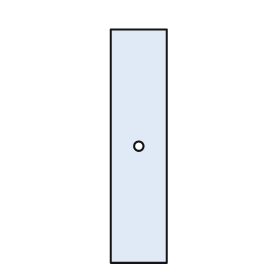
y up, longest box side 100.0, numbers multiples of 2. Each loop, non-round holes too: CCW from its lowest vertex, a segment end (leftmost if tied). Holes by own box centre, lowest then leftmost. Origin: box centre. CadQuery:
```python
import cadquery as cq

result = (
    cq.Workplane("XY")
    .moveTo(-12.0, -50.0)
    .lineTo(12.0, -50.0)
    .lineTo(12.0, 50.0)
    .lineTo(-12.0, 50.0)
    .close()
    .moveTo(0.0, 0.0)
    .circle(2.0)
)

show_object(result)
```